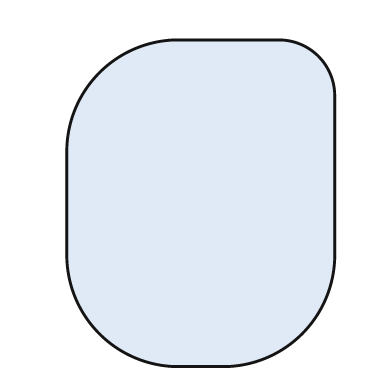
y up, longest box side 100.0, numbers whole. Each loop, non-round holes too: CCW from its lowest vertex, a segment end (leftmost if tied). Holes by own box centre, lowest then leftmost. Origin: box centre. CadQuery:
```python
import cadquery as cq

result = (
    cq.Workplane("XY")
    .moveTo(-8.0, -50.0)
    .lineTo(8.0, -50.0)
    .threePointArc((31.0, -40.0), (41.0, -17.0))
    .lineTo(41.0, 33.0)
    .threePointArc((36.0, 45.0), (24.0, 50.0))
    .lineTo(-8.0, 50.0)
    .threePointArc((-31.0, 40.0), (-41.0, 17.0))
    .lineTo(-41.0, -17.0)
    .threePointArc((-31.0, -40.0), (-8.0, -50.0))
    .close()
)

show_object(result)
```